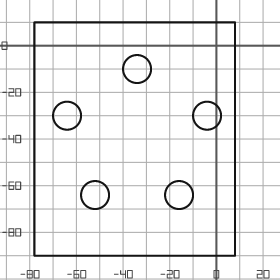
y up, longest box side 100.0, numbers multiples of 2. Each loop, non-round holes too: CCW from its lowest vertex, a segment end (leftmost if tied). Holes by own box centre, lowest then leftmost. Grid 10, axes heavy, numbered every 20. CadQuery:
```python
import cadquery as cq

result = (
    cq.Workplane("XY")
    .moveTo(-78.0, -90.0)
    .lineTo(8.0, -90.0)
    .lineTo(8.0, 10.0)
    .lineTo(-78.0, 10.0)
    .close()
    .moveTo(-52.0, -64.0)
    .circle(6.0)
    .moveTo(-16.0, -64.0)
    .circle(6.0)
    .moveTo(-64.0, -30.0)
    .circle(6.0)
    .moveTo(-4.0, -30.0)
    .circle(6.0)
    .moveTo(-34.0, -10.0)
    .circle(6.0)
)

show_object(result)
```